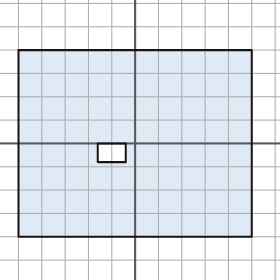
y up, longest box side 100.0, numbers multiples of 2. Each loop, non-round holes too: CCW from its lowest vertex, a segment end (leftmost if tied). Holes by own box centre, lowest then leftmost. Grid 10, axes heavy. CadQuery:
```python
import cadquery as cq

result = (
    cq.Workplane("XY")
    .moveTo(-50.0, -40.0)
    .lineTo(50.0, -40.0)
    .lineTo(50.0, 40.0)
    .lineTo(-50.0, 40.0)
    .close()
    .moveTo(-16.0, -8.0)
    .lineTo(-4.0, -8.0)
    .lineTo(-4.0, 0.0)
    .lineTo(-16.0, 0.0)
    .close()
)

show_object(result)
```